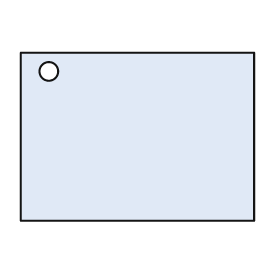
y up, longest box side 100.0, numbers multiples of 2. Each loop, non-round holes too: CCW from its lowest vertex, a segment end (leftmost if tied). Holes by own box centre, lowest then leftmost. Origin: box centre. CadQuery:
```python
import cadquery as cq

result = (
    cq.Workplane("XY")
    .moveTo(-50.0, -36.0)
    .lineTo(50.0, -36.0)
    .lineTo(50.0, 36.0)
    .lineTo(-50.0, 36.0)
    .close()
    .moveTo(-38.0, 28.0)
    .circle(4.0)
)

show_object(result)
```